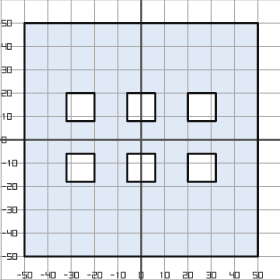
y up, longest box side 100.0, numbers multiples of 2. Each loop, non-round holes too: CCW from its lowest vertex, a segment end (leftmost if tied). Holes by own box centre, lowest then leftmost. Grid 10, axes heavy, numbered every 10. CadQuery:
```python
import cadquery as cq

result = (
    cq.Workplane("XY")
    .moveTo(-50.0, -50.0)
    .lineTo(50.0, -50.0)
    .lineTo(50.0, 50.0)
    .lineTo(-50.0, 50.0)
    .close()
    .moveTo(-32.0, -18.0)
    .lineTo(-20.0, -18.0)
    .lineTo(-20.0, -6.0)
    .lineTo(-32.0, -6.0)
    .close()
    .moveTo(-6.0, -18.0)
    .lineTo(6.0, -18.0)
    .lineTo(6.0, -6.0)
    .lineTo(-6.0, -6.0)
    .close()
    .moveTo(20.0, -18.0)
    .lineTo(32.0, -18.0)
    .lineTo(32.0, -6.0)
    .lineTo(20.0, -6.0)
    .close()
    .moveTo(-32.0, 8.0)
    .lineTo(-20.0, 8.0)
    .lineTo(-20.0, 20.0)
    .lineTo(-32.0, 20.0)
    .close()
    .moveTo(-6.0, 8.0)
    .lineTo(6.0, 8.0)
    .lineTo(6.0, 20.0)
    .lineTo(-6.0, 20.0)
    .close()
    .moveTo(20.0, 8.0)
    .lineTo(32.0, 8.0)
    .lineTo(32.0, 20.0)
    .lineTo(20.0, 20.0)
    .close()
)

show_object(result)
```